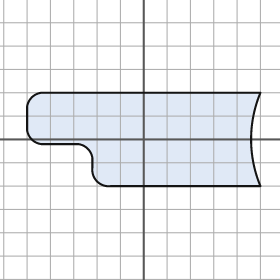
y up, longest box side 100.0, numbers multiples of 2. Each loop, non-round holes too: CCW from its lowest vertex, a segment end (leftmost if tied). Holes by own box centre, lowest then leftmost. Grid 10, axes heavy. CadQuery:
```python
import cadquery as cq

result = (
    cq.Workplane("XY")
    .moveTo(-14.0, -20.0)
    .lineTo(50.0, -20.0)
    .threePointArc((46.0, 0.0), (50.0, 20.0))
    .lineTo(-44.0, 20.0)
    .threePointArc((-48.0, 18.0), (-50.0, 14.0))
    .lineTo(-50.0, 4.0)
    .threePointArc((-48.0, 0.0), (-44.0, -2.0))
    .lineTo(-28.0, -2.0)
    .threePointArc((-24.0, -4.0), (-22.0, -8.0))
    .lineTo(-22.0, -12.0)
    .threePointArc((-20.0, -18.0), (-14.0, -20.0))
    .close()
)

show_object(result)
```